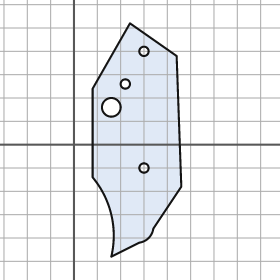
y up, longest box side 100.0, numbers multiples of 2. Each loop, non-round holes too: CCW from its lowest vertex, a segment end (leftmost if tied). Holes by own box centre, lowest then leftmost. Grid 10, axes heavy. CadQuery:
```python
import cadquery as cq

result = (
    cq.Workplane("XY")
    .moveTo(16.0, -48.0)
    .lineTo(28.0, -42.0)
    .threePointArc((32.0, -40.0), (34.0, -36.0))
    .lineTo(46.0, -18.0)
    .lineTo(44.0, 38.0)
    .lineTo(24.0, 52.0)
    .lineTo(8.0, 24.0)
    .lineTo(8.0, -14.0)
    .threePointArc((16.0, -30.0), (16.0, -48.0))
    .close()
    .moveTo(30.0, -10.0)
    .circle(2.0)
    .moveTo(16.0, 16.0)
    .circle(4.0)
    .moveTo(22.0, 26.0)
    .circle(2.0)
    .moveTo(30.0, 40.0)
    .circle(2.0)
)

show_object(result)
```